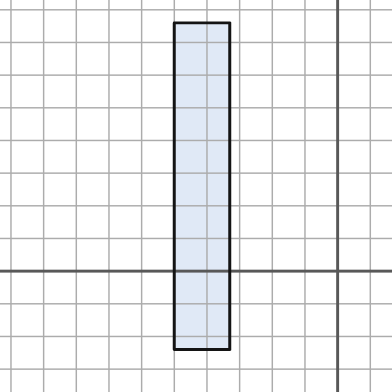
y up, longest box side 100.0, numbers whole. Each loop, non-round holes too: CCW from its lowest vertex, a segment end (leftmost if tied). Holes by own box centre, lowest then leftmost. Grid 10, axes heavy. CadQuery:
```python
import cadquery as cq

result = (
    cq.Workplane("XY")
    .moveTo(-50.0, -24.0)
    .lineTo(-33.0, -24.0)
    .lineTo(-33.0, 76.0)
    .lineTo(-50.0, 76.0)
    .close()
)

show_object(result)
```